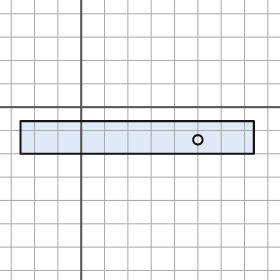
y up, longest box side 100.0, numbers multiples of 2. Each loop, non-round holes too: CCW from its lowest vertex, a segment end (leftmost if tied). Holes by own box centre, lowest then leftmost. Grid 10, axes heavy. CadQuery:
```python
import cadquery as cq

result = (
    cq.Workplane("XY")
    .moveTo(-26.0, -20.0)
    .lineTo(74.0, -20.0)
    .lineTo(74.0, -6.0)
    .lineTo(-26.0, -6.0)
    .close()
    .moveTo(50.0, -14.0)
    .circle(2.0)
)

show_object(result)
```